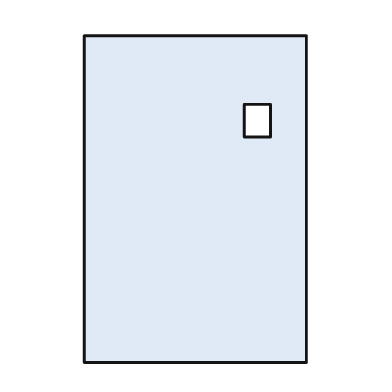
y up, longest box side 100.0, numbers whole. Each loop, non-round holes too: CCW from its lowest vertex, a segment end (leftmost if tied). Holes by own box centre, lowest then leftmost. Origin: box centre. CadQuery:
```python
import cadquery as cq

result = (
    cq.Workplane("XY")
    .moveTo(-34.0, -50.0)
    .lineTo(34.0, -50.0)
    .lineTo(34.0, 50.0)
    .lineTo(-34.0, 50.0)
    .close()
    .moveTo(15.0, 19.0)
    .lineTo(23.0, 19.0)
    .lineTo(23.0, 29.0)
    .lineTo(15.0, 29.0)
    .close()
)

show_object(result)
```